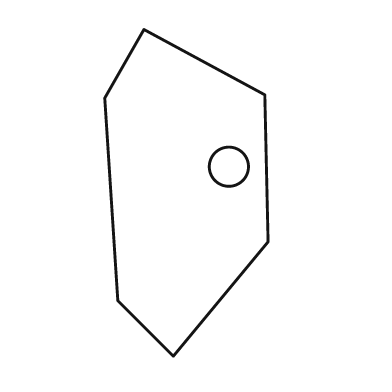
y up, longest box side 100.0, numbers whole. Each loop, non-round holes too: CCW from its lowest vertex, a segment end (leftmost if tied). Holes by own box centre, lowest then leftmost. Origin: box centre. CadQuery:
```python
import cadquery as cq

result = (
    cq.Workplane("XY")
    .moveTo(-4.0, -50.0)
    .lineTo(25.0, -15.0)
    .lineTo(24.0, 30.0)
    .lineTo(-13.0, 50.0)
    .lineTo(-25.0, 29.0)
    .lineTo(-21.0, -33.0)
    .close()
    .moveTo(13.0, 8.0)
    .circle(6.0)
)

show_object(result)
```